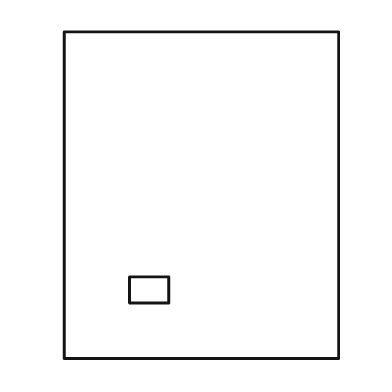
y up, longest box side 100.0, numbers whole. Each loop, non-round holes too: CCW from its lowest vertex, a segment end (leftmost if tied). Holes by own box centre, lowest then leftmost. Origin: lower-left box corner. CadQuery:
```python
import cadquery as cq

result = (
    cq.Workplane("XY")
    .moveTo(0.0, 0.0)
    .lineTo(84.0, 0.0)
    .lineTo(84.0, 100.0)
    .lineTo(0.0, 100.0)
    .close()
    .moveTo(20.0, 17.0)
    .lineTo(32.0, 17.0)
    .lineTo(32.0, 25.0)
    .lineTo(20.0, 25.0)
    .close()
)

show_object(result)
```